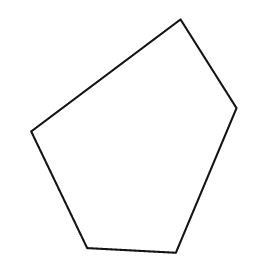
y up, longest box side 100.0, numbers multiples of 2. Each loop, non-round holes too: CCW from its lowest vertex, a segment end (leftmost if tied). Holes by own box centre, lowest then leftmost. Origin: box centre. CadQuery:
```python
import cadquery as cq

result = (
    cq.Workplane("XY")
    .moveTo(18.0, -50.0)
    .lineTo(44.0, 12.0)
    .lineTo(20.0, 50.0)
    .lineTo(-44.0, 2.0)
    .lineTo(-20.0, -48.0)
    .close()
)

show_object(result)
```